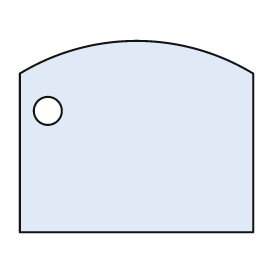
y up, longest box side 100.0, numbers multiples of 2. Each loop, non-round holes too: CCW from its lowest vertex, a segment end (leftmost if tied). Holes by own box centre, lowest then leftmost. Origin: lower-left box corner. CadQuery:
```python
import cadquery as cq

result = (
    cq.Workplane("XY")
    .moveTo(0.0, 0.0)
    .lineTo(100.0, 0.0)
    .lineTo(100.0, 68.0)
    .threePointArc((50.0, 82.0), (0.0, 68.0))
    .close()
    .moveTo(12.0, 52.0)
    .circle(6.0)
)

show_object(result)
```